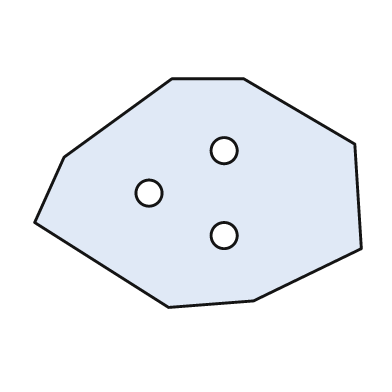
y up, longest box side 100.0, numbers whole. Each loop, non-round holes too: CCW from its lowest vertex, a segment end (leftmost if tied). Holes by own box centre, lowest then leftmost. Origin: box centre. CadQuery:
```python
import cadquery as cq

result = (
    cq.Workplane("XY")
    .moveTo(-9.0, -35.0)
    .lineTo(17.0, -33.0)
    .lineTo(50.0, -17.0)
    .lineTo(48.0, 15.0)
    .lineTo(14.0, 35.0)
    .lineTo(-8.0, 35.0)
    .lineTo(-41.0, 11.0)
    .lineTo(-50.0, -9.0)
    .close()
    .moveTo(8.0, -13.0)
    .circle(4.0)
    .moveTo(-15.0, 0.0)
    .circle(4.0)
    .moveTo(8.0, 13.0)
    .circle(4.0)
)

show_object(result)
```